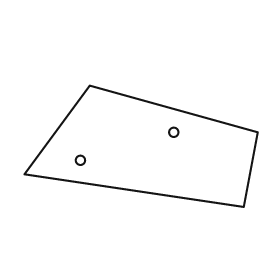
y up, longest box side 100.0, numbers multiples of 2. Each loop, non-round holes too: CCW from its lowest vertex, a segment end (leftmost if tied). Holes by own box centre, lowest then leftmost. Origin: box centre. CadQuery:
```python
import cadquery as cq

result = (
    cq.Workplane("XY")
    .moveTo(44.0, -26.0)
    .lineTo(50.0, 6.0)
    .lineTo(-22.0, 26.0)
    .lineTo(-50.0, -12.0)
    .close()
    .moveTo(-26.0, -6.0)
    .circle(2.0)
    .moveTo(14.0, 6.0)
    .circle(2.0)
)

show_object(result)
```